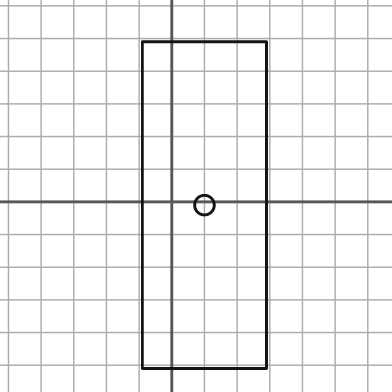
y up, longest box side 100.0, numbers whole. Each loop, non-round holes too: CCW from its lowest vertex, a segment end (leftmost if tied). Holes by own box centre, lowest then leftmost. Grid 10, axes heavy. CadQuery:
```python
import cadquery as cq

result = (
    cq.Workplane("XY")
    .moveTo(-9.0, -51.0)
    .lineTo(29.0, -51.0)
    .lineTo(29.0, 49.0)
    .lineTo(-9.0, 49.0)
    .close()
    .moveTo(10.0, -1.0)
    .circle(3.0)
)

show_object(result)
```